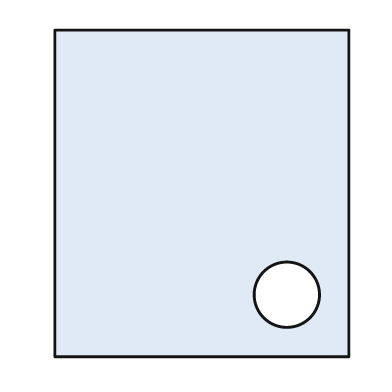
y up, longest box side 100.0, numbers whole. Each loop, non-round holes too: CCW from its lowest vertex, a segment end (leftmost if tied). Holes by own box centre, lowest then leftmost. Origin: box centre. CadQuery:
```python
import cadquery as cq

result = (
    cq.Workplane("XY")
    .moveTo(-45.0, -50.0)
    .lineTo(45.0, -50.0)
    .lineTo(45.0, 50.0)
    .lineTo(-45.0, 50.0)
    .close()
    .moveTo(26.0, -31.0)
    .circle(10.0)
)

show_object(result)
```